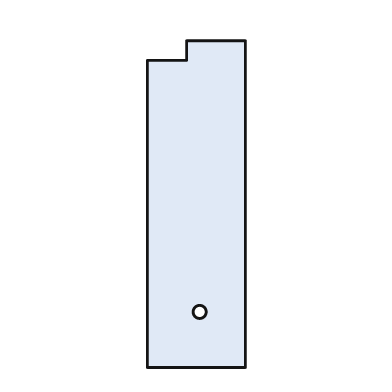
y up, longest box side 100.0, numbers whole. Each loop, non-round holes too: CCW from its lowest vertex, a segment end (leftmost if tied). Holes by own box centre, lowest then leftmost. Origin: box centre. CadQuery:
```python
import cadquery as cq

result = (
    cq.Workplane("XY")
    .moveTo(-15.0, -50.0)
    .lineTo(15.0, -50.0)
    .lineTo(15.0, 50.0)
    .lineTo(-3.0, 50.0)
    .lineTo(-3.0, 44.0)
    .lineTo(-15.0, 44.0)
    .close()
    .moveTo(1.0, -33.0)
    .circle(2.0)
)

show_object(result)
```